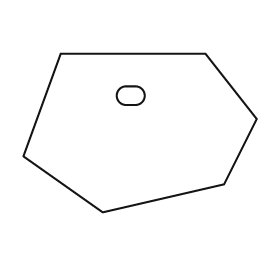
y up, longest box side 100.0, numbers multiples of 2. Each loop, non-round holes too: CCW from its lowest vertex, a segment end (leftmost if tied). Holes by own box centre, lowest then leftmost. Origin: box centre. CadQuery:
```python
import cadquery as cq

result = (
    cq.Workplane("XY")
    .moveTo(-16.0, -34.0)
    .lineTo(36.0, -22.0)
    .lineTo(50.0, 6.0)
    .lineTo(28.0, 34.0)
    .lineTo(-34.0, 34.0)
    .lineTo(-50.0, -10.0)
    .close()
    .moveTo(-6.0, 12.0)
    .lineTo(-2.0, 12.0)
    .threePointArc((2.0, 16.0), (-2.0, 20.0))
    .lineTo(-6.0, 20.0)
    .threePointArc((-10.0, 16.0), (-6.0, 12.0))
    .close()
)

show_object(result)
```